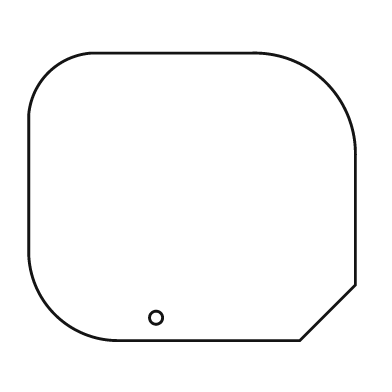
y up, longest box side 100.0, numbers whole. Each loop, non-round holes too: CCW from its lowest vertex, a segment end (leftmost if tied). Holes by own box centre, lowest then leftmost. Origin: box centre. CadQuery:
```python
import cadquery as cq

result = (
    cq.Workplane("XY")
    .moveTo(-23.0, -44.0)
    .lineTo(33.0, -44.0)
    .lineTo(50.0, -27.0)
    .lineTo(50.0, 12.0)
    .threePointArc((41.0, 35.0), (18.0, 44.0))
    .lineTo(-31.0, 44.0)
    .threePointArc((-44.0, 38.0), (-50.0, 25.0))
    .lineTo(-50.0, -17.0)
    .threePointArc((-42.0, -36.0), (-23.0, -44.0))
    .close()
    .moveTo(-11.0, -37.0)
    .circle(2.0)
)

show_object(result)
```